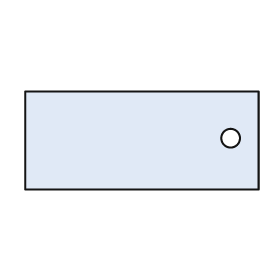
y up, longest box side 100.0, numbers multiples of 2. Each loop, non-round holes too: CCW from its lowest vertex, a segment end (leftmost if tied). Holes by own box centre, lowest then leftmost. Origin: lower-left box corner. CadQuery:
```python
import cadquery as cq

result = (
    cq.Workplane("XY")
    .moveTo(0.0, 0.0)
    .lineTo(100.0, 0.0)
    .lineTo(100.0, 42.0)
    .lineTo(0.0, 42.0)
    .close()
    .moveTo(88.0, 22.0)
    .circle(4.0)
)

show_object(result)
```